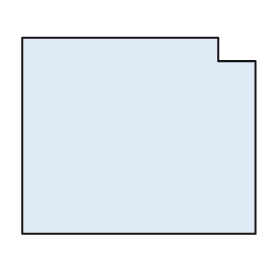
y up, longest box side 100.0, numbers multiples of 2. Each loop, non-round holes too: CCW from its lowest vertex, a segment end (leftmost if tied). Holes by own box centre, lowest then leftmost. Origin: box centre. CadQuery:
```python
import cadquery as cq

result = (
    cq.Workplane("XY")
    .moveTo(-50.0, -42.0)
    .lineTo(50.0, -42.0)
    .lineTo(50.0, 32.0)
    .lineTo(34.0, 32.0)
    .lineTo(34.0, 42.0)
    .lineTo(-50.0, 42.0)
    .close()
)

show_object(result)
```